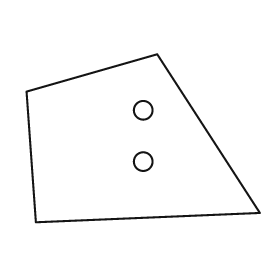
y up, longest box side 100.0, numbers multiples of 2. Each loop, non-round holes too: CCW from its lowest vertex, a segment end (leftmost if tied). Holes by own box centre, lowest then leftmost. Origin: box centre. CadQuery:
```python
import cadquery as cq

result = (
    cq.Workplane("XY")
    .moveTo(-46.0, -36.0)
    .lineTo(50.0, -32.0)
    .lineTo(6.0, 36.0)
    .lineTo(-50.0, 20.0)
    .close()
    .moveTo(0.0, -10.0)
    .circle(4.0)
    .moveTo(0.0, 12.0)
    .circle(4.0)
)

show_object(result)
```